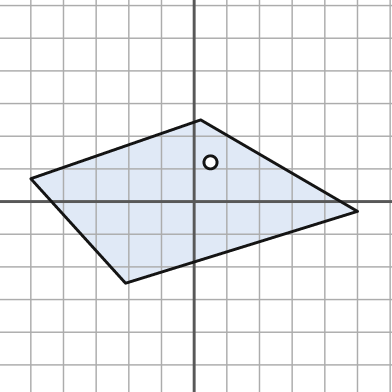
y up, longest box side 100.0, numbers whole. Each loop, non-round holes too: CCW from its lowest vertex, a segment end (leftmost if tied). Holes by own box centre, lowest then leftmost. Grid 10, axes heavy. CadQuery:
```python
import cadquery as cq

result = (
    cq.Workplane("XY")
    .moveTo(-21.0, -25.0)
    .lineTo(50.0, -3.0)
    .lineTo(2.0, 25.0)
    .lineTo(-50.0, 7.0)
    .close()
    .moveTo(5.0, 12.0)
    .circle(2.0)
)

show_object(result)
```